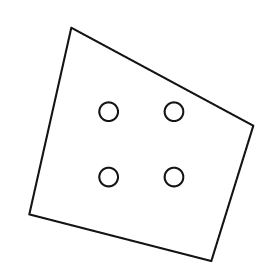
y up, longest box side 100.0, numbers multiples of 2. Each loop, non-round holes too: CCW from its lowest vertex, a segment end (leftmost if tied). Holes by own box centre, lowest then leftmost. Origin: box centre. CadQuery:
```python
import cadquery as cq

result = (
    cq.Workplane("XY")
    .moveTo(30.0, -50.0)
    .lineTo(48.0, 8.0)
    .lineTo(-30.0, 50.0)
    .lineTo(-48.0, -30.0)
    .close()
    .moveTo(-14.0, -14.0)
    .circle(4.0)
    .moveTo(14.0, -14.0)
    .circle(4.0)
    .moveTo(-14.0, 14.0)
    .circle(4.0)
    .moveTo(14.0, 14.0)
    .circle(4.0)
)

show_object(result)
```